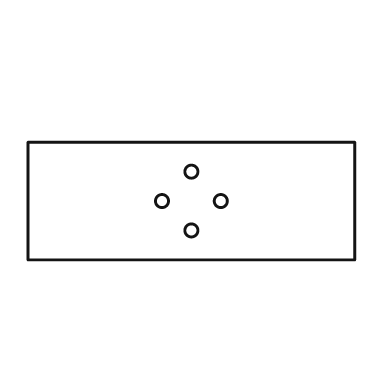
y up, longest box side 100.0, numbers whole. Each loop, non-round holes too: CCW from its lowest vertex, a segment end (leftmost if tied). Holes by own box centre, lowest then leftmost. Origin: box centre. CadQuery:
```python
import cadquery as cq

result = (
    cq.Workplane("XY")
    .moveTo(-50.0, -18.0)
    .lineTo(50.0, -18.0)
    .lineTo(50.0, 18.0)
    .lineTo(-50.0, 18.0)
    .close()
    .moveTo(0.0, -9.0)
    .circle(2.0)
    .moveTo(-9.0, 0.0)
    .circle(2.0)
    .moveTo(9.0, 0.0)
    .circle(2.0)
    .moveTo(0.0, 9.0)
    .circle(2.0)
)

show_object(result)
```